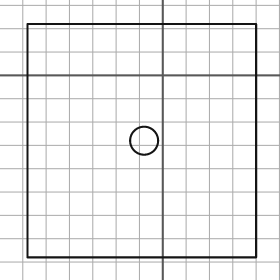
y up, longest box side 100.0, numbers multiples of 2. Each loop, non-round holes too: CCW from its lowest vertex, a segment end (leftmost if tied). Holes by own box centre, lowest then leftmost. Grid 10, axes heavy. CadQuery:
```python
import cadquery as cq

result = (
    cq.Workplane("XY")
    .moveTo(-58.0, -78.0)
    .lineTo(40.0, -78.0)
    .lineTo(40.0, 22.0)
    .lineTo(-58.0, 22.0)
    .close()
    .moveTo(-8.0, -28.0)
    .circle(6.0)
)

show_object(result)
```